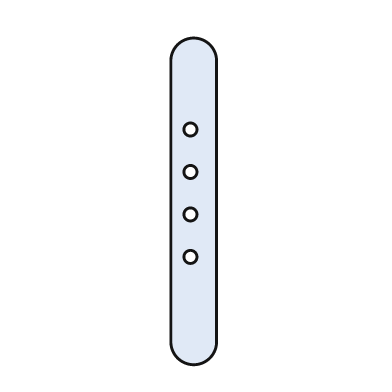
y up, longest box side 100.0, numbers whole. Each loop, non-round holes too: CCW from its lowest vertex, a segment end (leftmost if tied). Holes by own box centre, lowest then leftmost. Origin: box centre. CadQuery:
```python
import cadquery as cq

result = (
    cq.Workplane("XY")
    .moveTo(-7.0, -43.0)
    .threePointArc((0.0, -50.0), (7.0, -43.0))
    .lineTo(7.0, 43.0)
    .threePointArc((0.0, 50.0), (-7.0, 43.0))
    .close()
    .moveTo(-1.0, -17.0)
    .circle(2.0)
    .moveTo(-1.0, -4.0)
    .circle(2.0)
    .moveTo(-1.0, 9.0)
    .circle(2.0)
    .moveTo(-1.0, 22.0)
    .circle(2.0)
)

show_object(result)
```